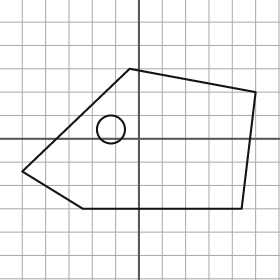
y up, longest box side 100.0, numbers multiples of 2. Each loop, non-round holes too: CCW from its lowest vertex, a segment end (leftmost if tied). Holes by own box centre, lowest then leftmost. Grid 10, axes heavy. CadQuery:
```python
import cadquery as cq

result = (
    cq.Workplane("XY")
    .moveTo(-24.0, -30.0)
    .lineTo(44.0, -30.0)
    .lineTo(50.0, 20.0)
    .lineTo(-4.0, 30.0)
    .lineTo(-50.0, -14.0)
    .close()
    .moveTo(-12.0, 4.0)
    .circle(6.0)
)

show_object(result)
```